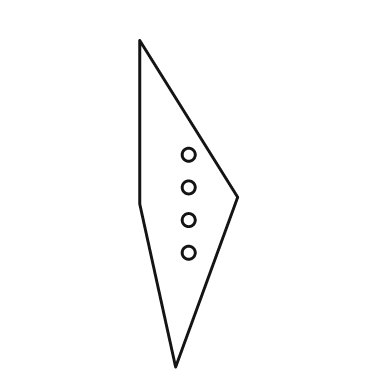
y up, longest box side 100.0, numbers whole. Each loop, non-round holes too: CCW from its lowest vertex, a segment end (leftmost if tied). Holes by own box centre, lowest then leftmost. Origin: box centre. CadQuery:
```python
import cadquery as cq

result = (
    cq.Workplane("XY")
    .moveTo(-4.0, -50.0)
    .lineTo(15.0, 2.0)
    .lineTo(-15.0, 50.0)
    .lineTo(-15.0, 0.0)
    .close()
    .moveTo(0.0, -15.0)
    .circle(2.0)
    .moveTo(0.0, -5.0)
    .circle(2.0)
    .moveTo(0.0, 5.0)
    .circle(2.0)
    .moveTo(0.0, 15.0)
    .circle(2.0)
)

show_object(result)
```